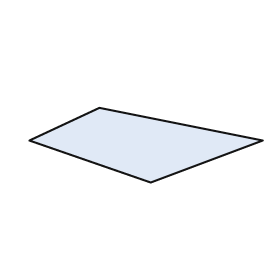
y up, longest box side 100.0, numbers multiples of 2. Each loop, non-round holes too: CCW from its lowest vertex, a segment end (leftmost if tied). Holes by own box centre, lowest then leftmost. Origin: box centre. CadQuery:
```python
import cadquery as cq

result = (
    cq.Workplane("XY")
    .moveTo(2.0, -16.0)
    .lineTo(50.0, 2.0)
    .lineTo(-20.0, 16.0)
    .lineTo(-50.0, 2.0)
    .close()
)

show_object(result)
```